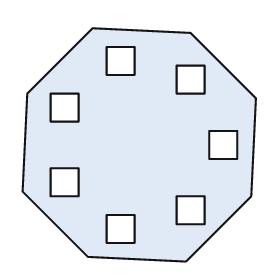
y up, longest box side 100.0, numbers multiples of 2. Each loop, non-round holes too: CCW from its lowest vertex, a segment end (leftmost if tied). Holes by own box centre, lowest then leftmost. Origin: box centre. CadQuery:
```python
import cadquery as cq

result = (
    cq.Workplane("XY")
    .moveTo(20.0, -50.0)
    .lineTo(48.0, -22.0)
    .lineTo(50.0, 20.0)
    .lineTo(22.0, 48.0)
    .lineTo(-20.0, 50.0)
    .lineTo(-48.0, 22.0)
    .lineTo(-50.0, -20.0)
    .lineTo(-22.0, -48.0)
    .close()
    .moveTo(-14.0, -42.0)
    .lineTo(-2.0, -42.0)
    .lineTo(-2.0, -30.0)
    .lineTo(-14.0, -30.0)
    .close()
    .moveTo(16.0, -34.0)
    .lineTo(28.0, -34.0)
    .lineTo(28.0, -22.0)
    .lineTo(16.0, -22.0)
    .close()
    .moveTo(-38.0, -22.0)
    .lineTo(-26.0, -22.0)
    .lineTo(-26.0, -10.0)
    .lineTo(-38.0, -10.0)
    .close()
    .moveTo(30.0, -6.0)
    .lineTo(42.0, -6.0)
    .lineTo(42.0, 6.0)
    .lineTo(30.0, 6.0)
    .close()
    .moveTo(-38.0, 10.0)
    .lineTo(-26.0, 10.0)
    .lineTo(-26.0, 22.0)
    .lineTo(-38.0, 22.0)
    .close()
    .moveTo(16.0, 22.0)
    .lineTo(28.0, 22.0)
    .lineTo(28.0, 34.0)
    .lineTo(16.0, 34.0)
    .close()
    .moveTo(-14.0, 30.0)
    .lineTo(-2.0, 30.0)
    .lineTo(-2.0, 42.0)
    .lineTo(-14.0, 42.0)
    .close()
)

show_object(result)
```